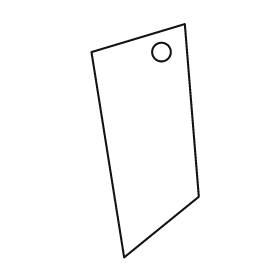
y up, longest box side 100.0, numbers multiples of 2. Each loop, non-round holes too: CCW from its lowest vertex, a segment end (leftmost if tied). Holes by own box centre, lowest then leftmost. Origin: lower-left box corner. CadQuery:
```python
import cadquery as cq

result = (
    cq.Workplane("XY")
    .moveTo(14.0, 0.0)
    .lineTo(46.0, 26.0)
    .lineTo(40.0, 100.0)
    .lineTo(0.0, 88.0)
    .close()
    .moveTo(30.0, 88.0)
    .circle(4.0)
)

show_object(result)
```